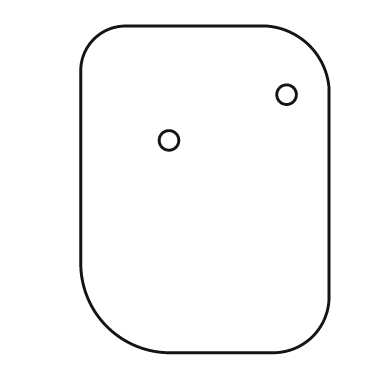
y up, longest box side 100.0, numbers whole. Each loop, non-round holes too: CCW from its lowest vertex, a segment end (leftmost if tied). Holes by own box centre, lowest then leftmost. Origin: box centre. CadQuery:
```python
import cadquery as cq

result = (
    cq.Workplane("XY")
    .moveTo(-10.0, -50.0)
    .lineTo(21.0, -50.0)
    .threePointArc((33.0, -45.0), (38.0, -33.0))
    .lineTo(38.0, 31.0)
    .threePointArc((32.0, 44.0), (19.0, 50.0))
    .lineTo(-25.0, 50.0)
    .threePointArc((-34.0, 46.0), (-38.0, 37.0))
    .lineTo(-38.0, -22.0)
    .threePointArc((-30.0, -42.0), (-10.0, -50.0))
    .close()
    .moveTo(-11.0, 15.0)
    .circle(3.0)
    .moveTo(25.0, 29.0)
    .circle(3.0)
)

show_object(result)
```